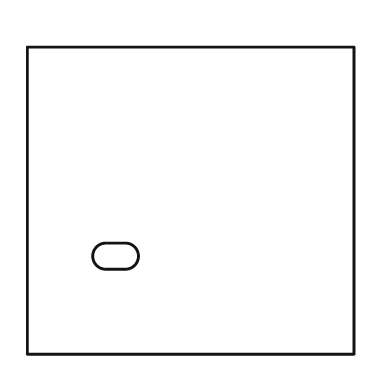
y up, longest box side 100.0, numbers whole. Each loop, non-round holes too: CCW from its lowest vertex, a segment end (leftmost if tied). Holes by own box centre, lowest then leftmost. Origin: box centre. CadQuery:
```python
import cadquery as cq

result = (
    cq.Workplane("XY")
    .moveTo(-50.0, -47.0)
    .lineTo(50.0, -47.0)
    .lineTo(50.0, 47.0)
    .lineTo(-50.0, 47.0)
    .close()
    .moveTo(-26.0, -21.0)
    .lineTo(-20.0, -21.0)
    .threePointArc((-16.0, -17.0), (-20.0, -13.0))
    .lineTo(-26.0, -13.0)
    .threePointArc((-30.0, -17.0), (-26.0, -21.0))
    .close()
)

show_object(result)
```